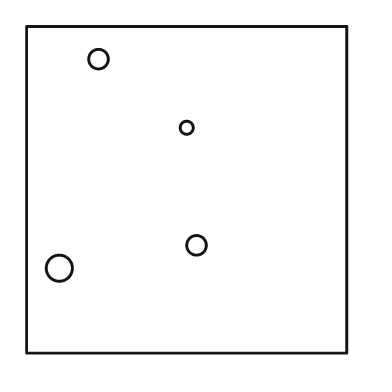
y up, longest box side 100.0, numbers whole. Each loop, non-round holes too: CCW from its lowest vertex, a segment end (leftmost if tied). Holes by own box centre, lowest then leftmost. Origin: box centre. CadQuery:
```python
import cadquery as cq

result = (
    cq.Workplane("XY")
    .moveTo(-49.0, -50.0)
    .lineTo(49.0, -50.0)
    .lineTo(49.0, 50.0)
    .lineTo(-49.0, 50.0)
    .close()
    .moveTo(-39.0, -24.0)
    .circle(4.0)
    .moveTo(3.0, -17.0)
    .circle(3.0)
    .moveTo(0.0, 19.0)
    .circle(2.0)
    .moveTo(-27.0, 40.0)
    .circle(3.0)
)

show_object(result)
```